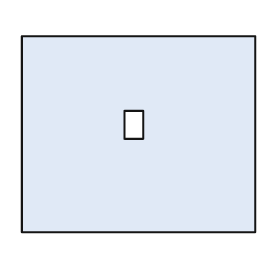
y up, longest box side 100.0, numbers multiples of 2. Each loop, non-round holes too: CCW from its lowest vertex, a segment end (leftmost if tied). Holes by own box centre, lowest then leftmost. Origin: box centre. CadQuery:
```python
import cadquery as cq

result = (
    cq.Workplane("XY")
    .moveTo(-50.0, -42.0)
    .lineTo(50.0, -42.0)
    .lineTo(50.0, 42.0)
    .lineTo(-50.0, 42.0)
    .close()
    .moveTo(-6.0, -2.0)
    .lineTo(2.0, -2.0)
    .lineTo(2.0, 10.0)
    .lineTo(-6.0, 10.0)
    .close()
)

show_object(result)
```